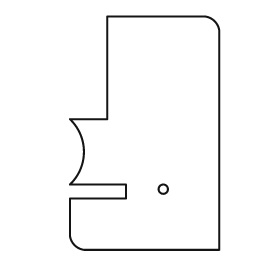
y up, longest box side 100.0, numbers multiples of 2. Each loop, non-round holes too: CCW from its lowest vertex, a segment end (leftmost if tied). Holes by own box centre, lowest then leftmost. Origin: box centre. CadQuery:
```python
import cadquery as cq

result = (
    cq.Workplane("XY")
    .moveTo(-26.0, -50.0)
    .lineTo(32.0, -50.0)
    .lineTo(32.0, 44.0)
    .threePointArc((30.0, 48.0), (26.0, 50.0))
    .lineTo(-16.0, 50.0)
    .lineTo(-16.0, 6.0)
    .lineTo(-32.0, 6.0)
    .threePointArc((-26.0, -8.0), (-32.0, -22.0))
    .lineTo(-8.0, -22.0)
    .lineTo(-8.0, -28.0)
    .lineTo(-32.0, -28.0)
    .lineTo(-32.0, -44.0)
    .threePointArc((-30.0, -48.0), (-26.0, -50.0))
    .close()
    .moveTo(8.0, -24.0)
    .circle(2.0)
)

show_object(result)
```